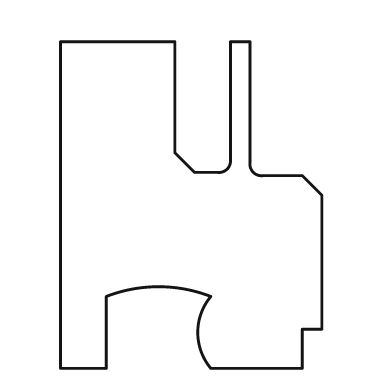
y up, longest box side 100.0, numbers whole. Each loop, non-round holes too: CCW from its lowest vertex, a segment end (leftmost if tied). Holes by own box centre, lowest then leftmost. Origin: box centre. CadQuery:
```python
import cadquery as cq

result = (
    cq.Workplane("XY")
    .moveTo(-40.0, -50.0)
    .lineTo(-26.0, -50.0)
    .lineTo(-26.0, -28.0)
    .threePointArc((-10.0, -25.0), (6.0, -28.0))
    .threePointArc((2.0, -39.0), (6.0, -50.0))
    .lineTo(34.0, -50.0)
    .lineTo(34.0, -38.0)
    .lineTo(40.0, -38.0)
    .lineTo(40.0, 3.0)
    .lineTo(34.0, 9.0)
    .lineTo(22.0, 9.0)
    .threePointArc((19.0, 10.0), (18.0, 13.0))
    .lineTo(18.0, 50.0)
    .lineTo(12.0, 50.0)
    .lineTo(12.0, 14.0)
    .threePointArc((11.0, 11.0), (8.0, 10.0))
    .lineTo(1.0, 10.0)
    .lineTo(-5.0, 16.0)
    .lineTo(-5.0, 50.0)
    .lineTo(-40.0, 50.0)
    .close()
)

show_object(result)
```